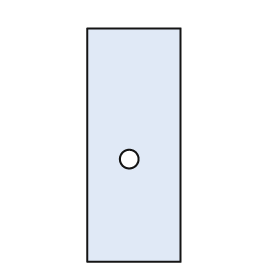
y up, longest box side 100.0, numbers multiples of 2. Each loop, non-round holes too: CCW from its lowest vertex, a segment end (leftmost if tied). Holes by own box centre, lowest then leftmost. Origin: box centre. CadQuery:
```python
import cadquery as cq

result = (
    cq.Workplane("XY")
    .moveTo(-20.0, -50.0)
    .lineTo(20.0, -50.0)
    .lineTo(20.0, 50.0)
    .lineTo(-20.0, 50.0)
    .close()
    .moveTo(-2.0, -6.0)
    .circle(4.0)
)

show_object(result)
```